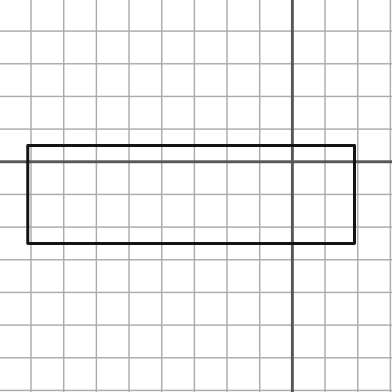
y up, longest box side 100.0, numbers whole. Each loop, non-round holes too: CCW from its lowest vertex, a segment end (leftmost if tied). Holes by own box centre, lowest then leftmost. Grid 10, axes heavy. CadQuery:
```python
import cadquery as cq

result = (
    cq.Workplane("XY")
    .moveTo(-81.0, -25.0)
    .lineTo(19.0, -25.0)
    .lineTo(19.0, 5.0)
    .lineTo(-81.0, 5.0)
    .close()
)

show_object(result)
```